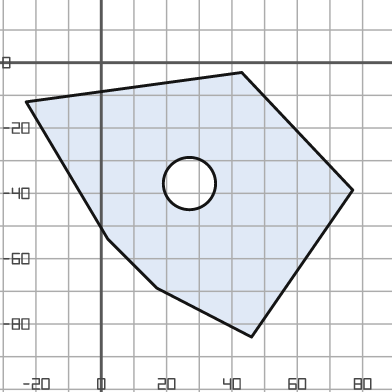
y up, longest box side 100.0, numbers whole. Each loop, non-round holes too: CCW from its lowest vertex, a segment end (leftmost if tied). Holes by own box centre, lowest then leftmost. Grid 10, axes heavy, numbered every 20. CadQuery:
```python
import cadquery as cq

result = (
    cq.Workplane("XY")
    .moveTo(46.0, -84.0)
    .lineTo(77.0, -39.0)
    .lineTo(43.0, -3.0)
    .lineTo(-23.0, -12.0)
    .lineTo(2.0, -54.0)
    .lineTo(17.0, -69.0)
    .close()
    .moveTo(27.0, -37.0)
    .circle(8.0)
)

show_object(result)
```